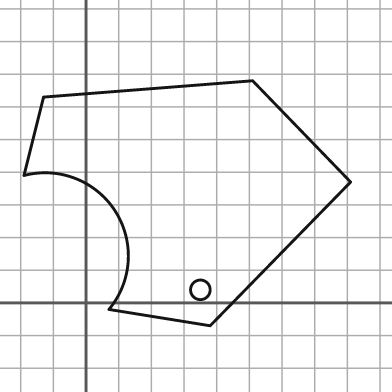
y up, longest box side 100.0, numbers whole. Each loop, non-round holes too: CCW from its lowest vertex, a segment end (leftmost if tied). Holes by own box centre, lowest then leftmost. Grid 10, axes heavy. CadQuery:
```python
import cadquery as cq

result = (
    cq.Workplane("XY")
    .moveTo(38.0, -7.0)
    .lineTo(81.0, 37.0)
    .lineTo(51.0, 68.0)
    .lineTo(-13.0, 63.0)
    .lineTo(-19.0, 39.0)
    .threePointArc((9.0, 28.0), (7.0, -2.0))
    .close()
    .moveTo(35.0, 4.0)
    .circle(3.0)
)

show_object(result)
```